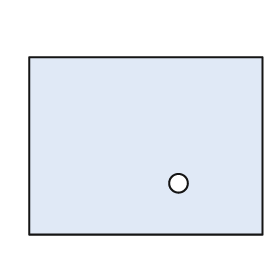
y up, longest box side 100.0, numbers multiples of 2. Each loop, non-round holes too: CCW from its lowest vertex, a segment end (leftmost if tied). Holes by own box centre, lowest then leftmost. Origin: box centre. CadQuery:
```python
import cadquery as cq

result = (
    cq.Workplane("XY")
    .moveTo(-50.0, -38.0)
    .lineTo(50.0, -38.0)
    .lineTo(50.0, 38.0)
    .lineTo(-50.0, 38.0)
    .close()
    .moveTo(14.0, -16.0)
    .circle(4.0)
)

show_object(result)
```